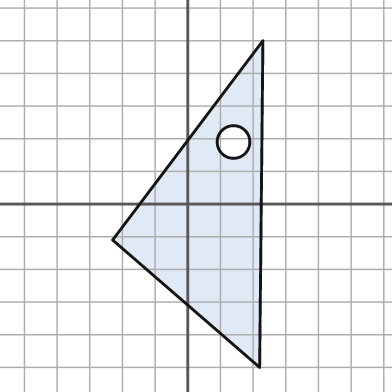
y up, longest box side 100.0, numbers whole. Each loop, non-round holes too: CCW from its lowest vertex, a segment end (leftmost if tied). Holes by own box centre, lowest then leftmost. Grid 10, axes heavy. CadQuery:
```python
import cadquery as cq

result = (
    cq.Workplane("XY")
    .moveTo(22.0, -50.0)
    .lineTo(23.0, 50.0)
    .lineTo(-23.0, -11.0)
    .close()
    .moveTo(14.0, 19.0)
    .circle(5.0)
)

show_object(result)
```